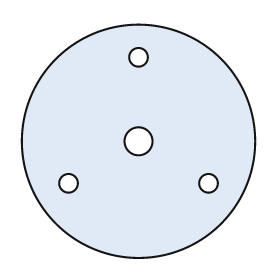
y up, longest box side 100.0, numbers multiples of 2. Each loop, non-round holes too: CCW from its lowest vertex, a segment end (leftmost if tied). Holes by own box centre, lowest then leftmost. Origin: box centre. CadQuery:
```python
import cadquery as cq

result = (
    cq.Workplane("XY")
    .moveTo(0.0, 0.0)
    .circle(50.0)
    .moveTo(-30.0, -18.0)
    .circle(4.0)
    .moveTo(30.0, -18.0)
    .circle(4.0)
    .moveTo(0.0, 0.0)
    .circle(6.0)
    .moveTo(0.0, 36.0)
    .circle(4.0)
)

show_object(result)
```